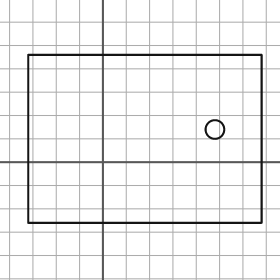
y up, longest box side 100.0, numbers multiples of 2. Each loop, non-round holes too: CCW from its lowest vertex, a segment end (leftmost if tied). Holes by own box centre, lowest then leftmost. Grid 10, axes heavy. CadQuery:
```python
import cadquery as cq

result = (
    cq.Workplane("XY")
    .moveTo(-32.0, -26.0)
    .lineTo(68.0, -26.0)
    .lineTo(68.0, 46.0)
    .lineTo(-32.0, 46.0)
    .close()
    .moveTo(48.0, 14.0)
    .circle(4.0)
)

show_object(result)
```